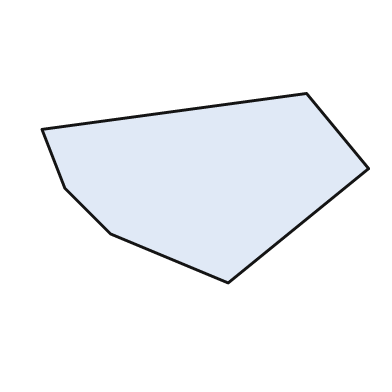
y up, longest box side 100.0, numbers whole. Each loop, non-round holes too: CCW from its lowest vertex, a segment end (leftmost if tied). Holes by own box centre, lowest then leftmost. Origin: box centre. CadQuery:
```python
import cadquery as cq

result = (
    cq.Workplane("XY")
    .moveTo(7.0, -29.0)
    .lineTo(50.0, 6.0)
    .lineTo(31.0, 29.0)
    .lineTo(-50.0, 18.0)
    .lineTo(-43.0, 0.0)
    .lineTo(-29.0, -14.0)
    .close()
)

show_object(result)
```